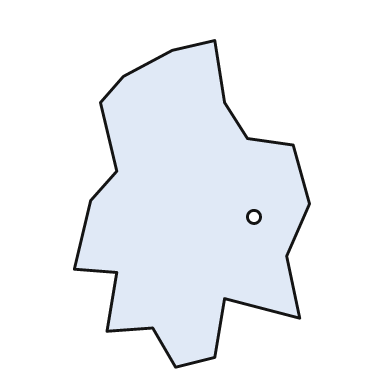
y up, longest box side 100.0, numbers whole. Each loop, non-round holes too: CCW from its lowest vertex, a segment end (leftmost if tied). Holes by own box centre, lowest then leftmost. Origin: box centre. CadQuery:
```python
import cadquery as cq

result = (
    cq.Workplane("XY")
    .moveTo(-5.0, -50.0)
    .lineTo(7.0, -47.0)
    .lineTo(10.0, -29.0)
    .lineTo(33.0, -35.0)
    .lineTo(29.0, -16.0)
    .lineTo(36.0, 0.0)
    .lineTo(31.0, 18.0)
    .lineTo(17.0, 20.0)
    .lineTo(10.0, 31.0)
    .lineTo(7.0, 50.0)
    .lineTo(-6.0, 47.0)
    .lineTo(-21.0, 39.0)
    .lineTo(-28.0, 31.0)
    .lineTo(-23.0, 10.0)
    .lineTo(-31.0, 1.0)
    .lineTo(-36.0, -20.0)
    .lineTo(-23.0, -21.0)
    .lineTo(-26.0, -39.0)
    .lineTo(-12.0, -38.0)
    .close()
    .moveTo(19.0, -4.0)
    .circle(2.0)
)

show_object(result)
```